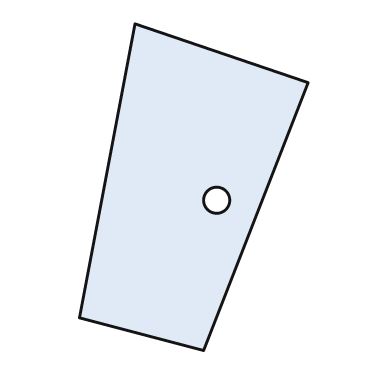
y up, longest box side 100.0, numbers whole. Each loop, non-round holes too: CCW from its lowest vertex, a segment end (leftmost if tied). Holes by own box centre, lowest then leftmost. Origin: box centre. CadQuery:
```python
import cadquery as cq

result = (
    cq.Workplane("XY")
    .moveTo(3.0, -50.0)
    .lineTo(35.0, 32.0)
    .lineTo(-18.0, 50.0)
    .lineTo(-35.0, -40.0)
    .close()
    .moveTo(7.0, -4.0)
    .circle(4.0)
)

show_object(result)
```